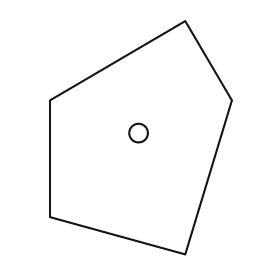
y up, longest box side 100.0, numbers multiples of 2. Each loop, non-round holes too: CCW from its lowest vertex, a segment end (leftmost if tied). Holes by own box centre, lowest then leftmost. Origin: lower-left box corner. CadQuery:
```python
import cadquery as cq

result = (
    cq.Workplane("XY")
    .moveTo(58.0, 0.0)
    .lineTo(78.0, 66.0)
    .lineTo(58.0, 100.0)
    .lineTo(0.0, 66.0)
    .lineTo(0.0, 16.0)
    .close()
    .moveTo(38.0, 52.0)
    .circle(4.0)
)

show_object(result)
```